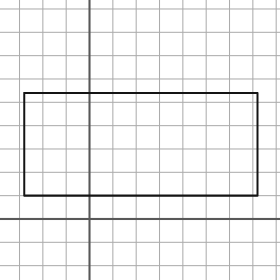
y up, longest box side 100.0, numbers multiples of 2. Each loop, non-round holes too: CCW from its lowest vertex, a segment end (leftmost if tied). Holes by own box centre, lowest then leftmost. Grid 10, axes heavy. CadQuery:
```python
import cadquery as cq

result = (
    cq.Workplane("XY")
    .moveTo(-28.0, 10.0)
    .lineTo(72.0, 10.0)
    .lineTo(72.0, 54.0)
    .lineTo(-28.0, 54.0)
    .close()
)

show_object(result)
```